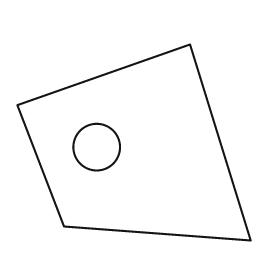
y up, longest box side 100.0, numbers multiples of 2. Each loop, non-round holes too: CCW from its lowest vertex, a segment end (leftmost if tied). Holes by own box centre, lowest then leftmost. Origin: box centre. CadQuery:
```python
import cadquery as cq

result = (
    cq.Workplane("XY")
    .moveTo(50.0, -42.0)
    .lineTo(24.0, 42.0)
    .lineTo(-50.0, 16.0)
    .lineTo(-30.0, -36.0)
    .close()
    .moveTo(-16.0, -2.0)
    .circle(10.0)
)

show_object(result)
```